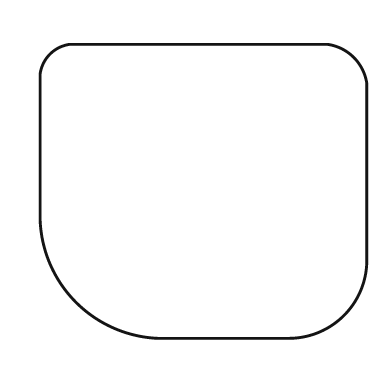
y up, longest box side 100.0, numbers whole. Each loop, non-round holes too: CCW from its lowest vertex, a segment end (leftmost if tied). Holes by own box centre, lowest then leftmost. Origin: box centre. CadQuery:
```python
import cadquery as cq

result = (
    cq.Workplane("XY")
    .moveTo(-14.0, -45.0)
    .lineTo(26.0, -45.0)
    .threePointArc((43.0, -38.0), (50.0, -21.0))
    .lineTo(50.0, 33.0)
    .threePointArc((46.0, 41.0), (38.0, 45.0))
    .lineTo(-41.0, 45.0)
    .threePointArc((-47.0, 42.0), (-50.0, 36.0))
    .lineTo(-50.0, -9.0)
    .threePointArc((-39.0, -34.0), (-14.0, -45.0))
    .close()
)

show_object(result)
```